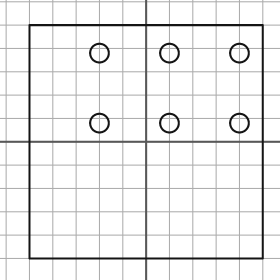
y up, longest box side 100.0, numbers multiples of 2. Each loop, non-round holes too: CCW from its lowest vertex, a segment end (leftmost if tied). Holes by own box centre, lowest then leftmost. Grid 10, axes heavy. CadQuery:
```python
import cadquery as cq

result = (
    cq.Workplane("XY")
    .moveTo(-50.0, -50.0)
    .lineTo(50.0, -50.0)
    .lineTo(50.0, 50.0)
    .lineTo(-50.0, 50.0)
    .close()
    .moveTo(-20.0, 8.0)
    .circle(4.0)
    .moveTo(10.0, 8.0)
    .circle(4.0)
    .moveTo(40.0, 8.0)
    .circle(4.0)
    .moveTo(-20.0, 38.0)
    .circle(4.0)
    .moveTo(10.0, 38.0)
    .circle(4.0)
    .moveTo(40.0, 38.0)
    .circle(4.0)
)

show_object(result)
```